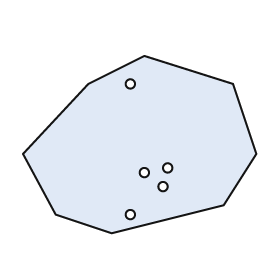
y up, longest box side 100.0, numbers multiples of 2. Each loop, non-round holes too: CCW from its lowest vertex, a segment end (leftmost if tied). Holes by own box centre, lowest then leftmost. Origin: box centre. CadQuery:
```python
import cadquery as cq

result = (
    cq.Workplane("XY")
    .moveTo(-12.0, -38.0)
    .lineTo(36.0, -26.0)
    .lineTo(50.0, -4.0)
    .lineTo(40.0, 26.0)
    .lineTo(2.0, 38.0)
    .lineTo(-22.0, 26.0)
    .lineTo(-50.0, -4.0)
    .lineTo(-36.0, -30.0)
    .close()
    .moveTo(-4.0, -30.0)
    .circle(2.0)
    .moveTo(10.0, -18.0)
    .circle(2.0)
    .moveTo(2.0, -12.0)
    .circle(2.0)
    .moveTo(12.0, -10.0)
    .circle(2.0)
    .moveTo(-4.0, 26.0)
    .circle(2.0)
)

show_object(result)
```